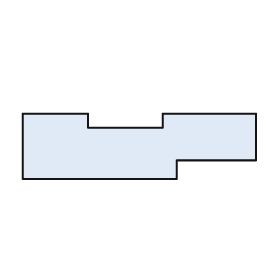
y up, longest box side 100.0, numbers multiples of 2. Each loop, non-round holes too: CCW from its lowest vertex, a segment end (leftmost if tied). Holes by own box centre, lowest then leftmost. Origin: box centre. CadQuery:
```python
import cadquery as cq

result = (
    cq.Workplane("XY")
    .moveTo(-50.0, -14.0)
    .lineTo(16.0, -14.0)
    .lineTo(16.0, -6.0)
    .lineTo(50.0, -6.0)
    .lineTo(50.0, 14.0)
    .lineTo(10.0, 14.0)
    .lineTo(10.0, 8.0)
    .lineTo(-22.0, 8.0)
    .lineTo(-22.0, 14.0)
    .lineTo(-50.0, 14.0)
    .close()
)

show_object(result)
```